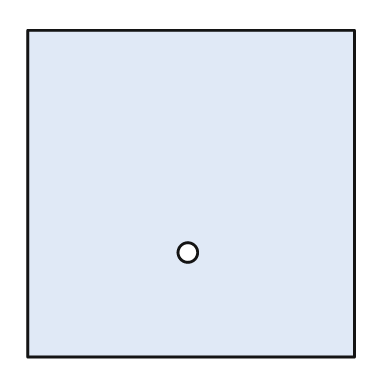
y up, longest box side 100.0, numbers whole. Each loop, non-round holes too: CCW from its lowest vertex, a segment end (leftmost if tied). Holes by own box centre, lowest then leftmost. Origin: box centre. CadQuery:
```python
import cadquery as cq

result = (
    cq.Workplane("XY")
    .moveTo(-50.0, -50.0)
    .lineTo(50.0, -50.0)
    .lineTo(50.0, 50.0)
    .lineTo(-50.0, 50.0)
    .close()
    .moveTo(-1.0, -18.0)
    .circle(3.0)
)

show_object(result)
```